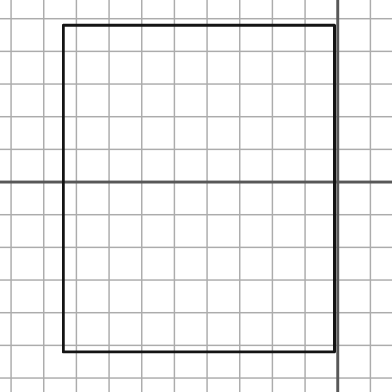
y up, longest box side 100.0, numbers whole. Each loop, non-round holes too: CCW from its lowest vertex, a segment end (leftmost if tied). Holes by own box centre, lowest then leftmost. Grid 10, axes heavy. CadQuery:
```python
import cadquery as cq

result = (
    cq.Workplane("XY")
    .moveTo(-84.0, -52.0)
    .lineTo(-1.0, -52.0)
    .lineTo(-1.0, 48.0)
    .lineTo(-84.0, 48.0)
    .close()
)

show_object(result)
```